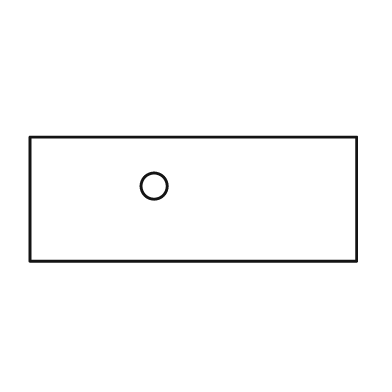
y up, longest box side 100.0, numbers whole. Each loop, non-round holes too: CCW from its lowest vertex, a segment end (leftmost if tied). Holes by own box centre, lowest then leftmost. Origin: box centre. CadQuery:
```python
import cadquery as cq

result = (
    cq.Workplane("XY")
    .moveTo(-50.0, -19.0)
    .lineTo(50.0, -19.0)
    .lineTo(50.0, 19.0)
    .lineTo(-50.0, 19.0)
    .close()
    .moveTo(-12.0, 4.0)
    .circle(4.0)
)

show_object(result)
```